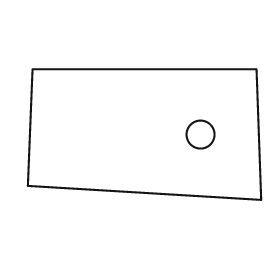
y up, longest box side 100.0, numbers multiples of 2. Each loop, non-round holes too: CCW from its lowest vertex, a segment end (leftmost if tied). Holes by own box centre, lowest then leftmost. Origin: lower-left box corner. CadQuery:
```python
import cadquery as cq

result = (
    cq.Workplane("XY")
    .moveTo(100.0, 0.0)
    .lineTo(98.0, 56.0)
    .lineTo(2.0, 56.0)
    .lineTo(0.0, 6.0)
    .close()
    .moveTo(74.0, 28.0)
    .circle(6.0)
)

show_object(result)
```